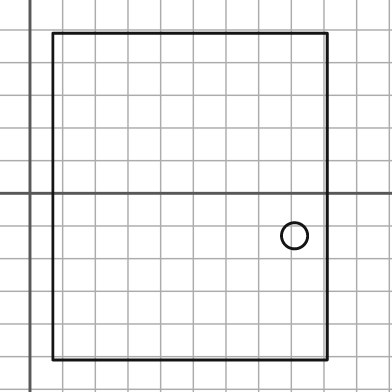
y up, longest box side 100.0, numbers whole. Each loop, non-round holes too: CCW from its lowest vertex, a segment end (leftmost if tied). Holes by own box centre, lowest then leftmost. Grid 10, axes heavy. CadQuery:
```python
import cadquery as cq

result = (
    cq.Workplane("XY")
    .moveTo(7.0, -51.0)
    .lineTo(91.0, -51.0)
    .lineTo(91.0, 49.0)
    .lineTo(7.0, 49.0)
    .close()
    .moveTo(81.0, -13.0)
    .circle(4.0)
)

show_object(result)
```